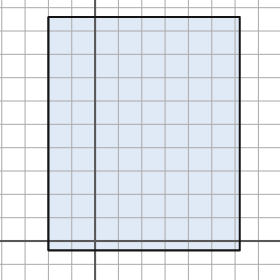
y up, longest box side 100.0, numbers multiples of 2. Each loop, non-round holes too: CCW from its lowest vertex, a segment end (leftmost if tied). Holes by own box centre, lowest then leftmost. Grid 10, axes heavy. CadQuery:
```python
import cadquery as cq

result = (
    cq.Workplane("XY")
    .moveTo(-20.0, -4.0)
    .lineTo(62.0, -4.0)
    .lineTo(62.0, 96.0)
    .lineTo(-20.0, 96.0)
    .close()
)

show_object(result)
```